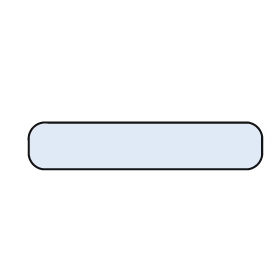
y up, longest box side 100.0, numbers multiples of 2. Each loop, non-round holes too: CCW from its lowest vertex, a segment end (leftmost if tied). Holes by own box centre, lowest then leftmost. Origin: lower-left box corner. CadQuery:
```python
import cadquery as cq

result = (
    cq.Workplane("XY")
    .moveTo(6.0, 0.0)
    .lineTo(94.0, 0.0)
    .threePointArc((98.0, 2.0), (100.0, 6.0))
    .lineTo(100.0, 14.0)
    .threePointArc((98.0, 18.0), (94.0, 20.0))
    .lineTo(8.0, 20.0)
    .threePointArc((2.0, 18.0), (0.0, 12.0))
    .lineTo(0.0, 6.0)
    .threePointArc((2.0, 2.0), (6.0, 0.0))
    .close()
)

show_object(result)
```